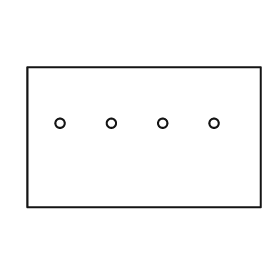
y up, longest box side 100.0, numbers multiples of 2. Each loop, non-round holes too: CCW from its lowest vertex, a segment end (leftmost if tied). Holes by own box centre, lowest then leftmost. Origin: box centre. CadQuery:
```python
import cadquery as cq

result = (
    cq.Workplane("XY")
    .moveTo(-50.0, -30.0)
    .lineTo(50.0, -30.0)
    .lineTo(50.0, 30.0)
    .lineTo(-50.0, 30.0)
    .close()
    .moveTo(-36.0, 6.0)
    .circle(2.0)
    .moveTo(-14.0, 6.0)
    .circle(2.0)
    .moveTo(8.0, 6.0)
    .circle(2.0)
    .moveTo(30.0, 6.0)
    .circle(2.0)
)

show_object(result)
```